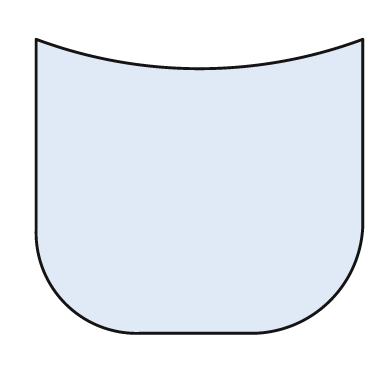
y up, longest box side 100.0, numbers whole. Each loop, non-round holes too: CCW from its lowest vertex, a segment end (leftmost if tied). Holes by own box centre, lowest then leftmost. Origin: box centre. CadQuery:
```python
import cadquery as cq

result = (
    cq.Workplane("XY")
    .moveTo(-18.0, -45.0)
    .lineTo(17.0, -45.0)
    .threePointArc((40.0, -35.0), (50.0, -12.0))
    .lineTo(50.0, 45.0)
    .threePointArc((0.0, 36.0), (-50.0, 45.0))
    .lineTo(-50.0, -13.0)
    .threePointArc((-41.0, -36.0), (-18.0, -45.0))
    .close()
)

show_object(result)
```